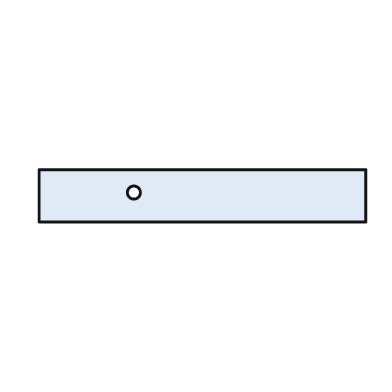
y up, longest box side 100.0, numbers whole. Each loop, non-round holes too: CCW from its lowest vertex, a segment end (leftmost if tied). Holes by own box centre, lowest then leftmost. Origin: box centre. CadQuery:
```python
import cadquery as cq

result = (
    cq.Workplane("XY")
    .moveTo(-50.0, -8.0)
    .lineTo(50.0, -8.0)
    .lineTo(50.0, 8.0)
    .lineTo(-50.0, 8.0)
    .close()
    .moveTo(-21.0, 1.0)
    .circle(2.0)
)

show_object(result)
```